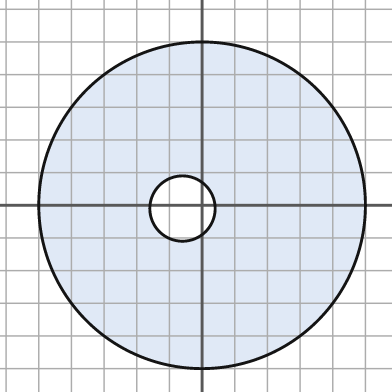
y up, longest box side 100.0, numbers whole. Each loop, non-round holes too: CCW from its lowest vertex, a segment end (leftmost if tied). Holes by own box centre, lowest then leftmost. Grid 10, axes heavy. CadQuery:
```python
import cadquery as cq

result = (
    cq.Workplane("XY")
    .moveTo(0.0, 0.0)
    .circle(50.0)
    .moveTo(-6.0, -1.0)
    .circle(10.0)
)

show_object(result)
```